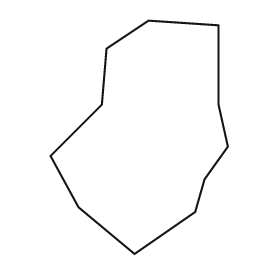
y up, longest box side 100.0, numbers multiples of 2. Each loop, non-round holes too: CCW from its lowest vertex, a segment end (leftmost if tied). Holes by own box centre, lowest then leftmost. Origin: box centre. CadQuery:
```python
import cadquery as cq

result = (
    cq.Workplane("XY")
    .moveTo(-2.0, -50.0)
    .lineTo(24.0, -32.0)
    .lineTo(28.0, -18.0)
    .lineTo(38.0, -4.0)
    .lineTo(34.0, 14.0)
    .lineTo(34.0, 48.0)
    .lineTo(4.0, 50.0)
    .lineTo(-14.0, 38.0)
    .lineTo(-16.0, 14.0)
    .lineTo(-38.0, -8.0)
    .lineTo(-26.0, -30.0)
    .close()
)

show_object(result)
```